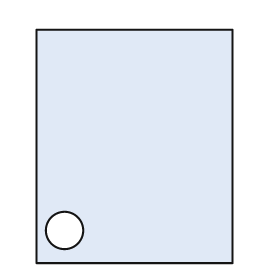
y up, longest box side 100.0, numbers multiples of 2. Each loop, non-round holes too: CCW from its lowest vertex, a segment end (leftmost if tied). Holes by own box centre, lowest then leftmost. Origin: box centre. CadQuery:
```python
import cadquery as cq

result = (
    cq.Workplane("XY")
    .moveTo(-42.0, -50.0)
    .lineTo(42.0, -50.0)
    .lineTo(42.0, 50.0)
    .lineTo(-42.0, 50.0)
    .close()
    .moveTo(-30.0, -36.0)
    .circle(8.0)
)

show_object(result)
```